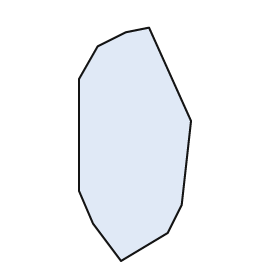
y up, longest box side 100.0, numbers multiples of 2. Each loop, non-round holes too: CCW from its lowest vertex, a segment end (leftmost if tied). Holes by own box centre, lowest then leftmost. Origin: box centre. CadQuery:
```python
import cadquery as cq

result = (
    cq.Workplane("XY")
    .moveTo(-6.0, -50.0)
    .lineTo(14.0, -38.0)
    .lineTo(20.0, -26.0)
    .lineTo(24.0, 10.0)
    .lineTo(6.0, 50.0)
    .lineTo(-4.0, 48.0)
    .lineTo(-16.0, 42.0)
    .lineTo(-24.0, 28.0)
    .lineTo(-24.0, -20.0)
    .lineTo(-18.0, -34.0)
    .close()
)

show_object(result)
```